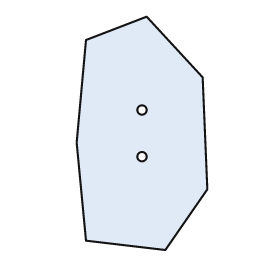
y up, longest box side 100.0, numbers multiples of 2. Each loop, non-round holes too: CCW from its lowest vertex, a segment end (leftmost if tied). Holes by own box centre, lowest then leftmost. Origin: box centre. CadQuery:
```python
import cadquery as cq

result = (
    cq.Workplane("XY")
    .moveTo(10.0, -50.0)
    .lineTo(28.0, -24.0)
    .lineTo(26.0, 24.0)
    .lineTo(2.0, 50.0)
    .lineTo(-24.0, 40.0)
    .lineTo(-28.0, -4.0)
    .lineTo(-24.0, -46.0)
    .close()
    .moveTo(0.0, -10.0)
    .circle(2.0)
    .moveTo(0.0, 10.0)
    .circle(2.0)
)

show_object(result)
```